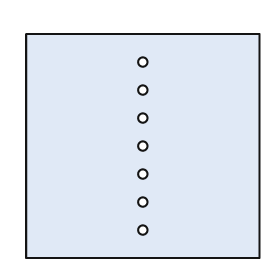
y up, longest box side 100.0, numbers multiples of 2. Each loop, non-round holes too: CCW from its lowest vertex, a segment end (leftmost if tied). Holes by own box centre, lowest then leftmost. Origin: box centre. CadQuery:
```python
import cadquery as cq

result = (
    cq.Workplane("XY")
    .moveTo(-50.0, -48.0)
    .lineTo(50.0, -48.0)
    .lineTo(50.0, 48.0)
    .lineTo(-50.0, 48.0)
    .close()
    .moveTo(0.0, -36.0)
    .circle(2.0)
    .moveTo(0.0, -24.0)
    .circle(2.0)
    .moveTo(0.0, -12.0)
    .circle(2.0)
    .moveTo(0.0, 0.0)
    .circle(2.0)
    .moveTo(0.0, 12.0)
    .circle(2.0)
    .moveTo(0.0, 24.0)
    .circle(2.0)
    .moveTo(0.0, 36.0)
    .circle(2.0)
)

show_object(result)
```